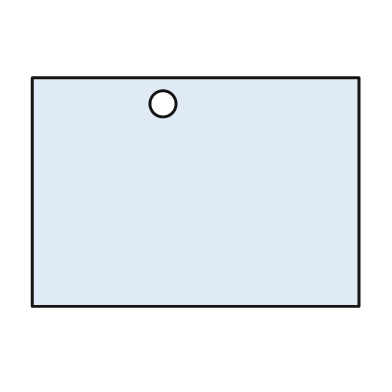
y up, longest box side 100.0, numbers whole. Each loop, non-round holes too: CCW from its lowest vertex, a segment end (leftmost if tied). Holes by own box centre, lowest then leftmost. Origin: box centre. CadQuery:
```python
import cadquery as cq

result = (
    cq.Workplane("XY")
    .moveTo(-50.0, -35.0)
    .lineTo(50.0, -35.0)
    .lineTo(50.0, 35.0)
    .lineTo(-50.0, 35.0)
    .close()
    .moveTo(-10.0, 27.0)
    .circle(4.0)
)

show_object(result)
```